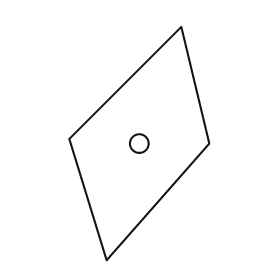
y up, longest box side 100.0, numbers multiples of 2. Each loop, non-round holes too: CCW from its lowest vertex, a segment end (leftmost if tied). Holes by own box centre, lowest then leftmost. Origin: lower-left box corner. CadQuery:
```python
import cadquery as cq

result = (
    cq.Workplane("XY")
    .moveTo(16.0, 0.0)
    .lineTo(60.0, 50.0)
    .lineTo(48.0, 100.0)
    .lineTo(0.0, 52.0)
    .close()
    .moveTo(30.0, 50.0)
    .circle(4.0)
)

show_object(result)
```